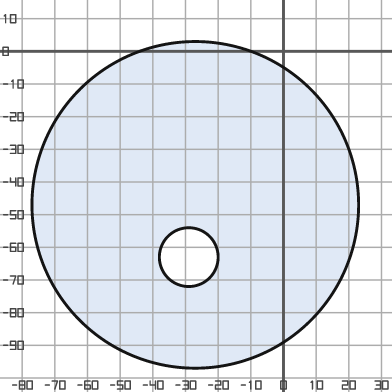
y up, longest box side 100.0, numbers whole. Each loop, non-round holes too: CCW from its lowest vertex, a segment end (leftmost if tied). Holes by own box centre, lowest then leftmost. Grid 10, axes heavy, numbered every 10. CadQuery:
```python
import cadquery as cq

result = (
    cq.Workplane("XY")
    .moveTo(-27.0, -47.0)
    .circle(50.0)
    .moveTo(-29.0, -63.0)
    .circle(9.0)
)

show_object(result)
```